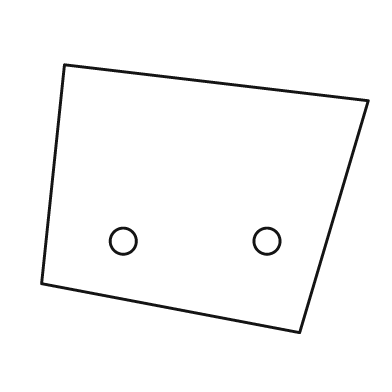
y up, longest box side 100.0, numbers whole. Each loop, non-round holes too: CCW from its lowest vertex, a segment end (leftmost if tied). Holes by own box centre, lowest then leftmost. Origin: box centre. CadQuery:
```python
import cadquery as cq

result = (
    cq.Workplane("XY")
    .moveTo(29.0, -41.0)
    .lineTo(50.0, 30.0)
    .lineTo(-43.0, 41.0)
    .lineTo(-50.0, -26.0)
    .close()
    .moveTo(-25.0, -13.0)
    .circle(4.0)
    .moveTo(19.0, -13.0)
    .circle(4.0)
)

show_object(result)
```